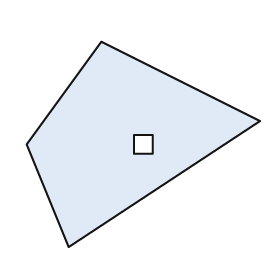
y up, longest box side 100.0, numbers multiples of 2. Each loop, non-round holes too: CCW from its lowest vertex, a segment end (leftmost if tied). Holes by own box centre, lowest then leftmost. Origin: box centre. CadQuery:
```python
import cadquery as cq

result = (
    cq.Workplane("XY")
    .moveTo(-32.0, -44.0)
    .lineTo(50.0, 10.0)
    .lineTo(-18.0, 44.0)
    .lineTo(-50.0, 0.0)
    .close()
    .moveTo(-4.0, -4.0)
    .lineTo(4.0, -4.0)
    .lineTo(4.0, 4.0)
    .lineTo(-4.0, 4.0)
    .close()
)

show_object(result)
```